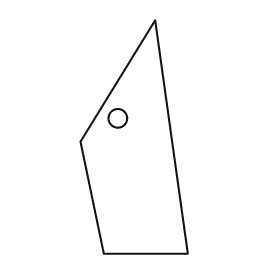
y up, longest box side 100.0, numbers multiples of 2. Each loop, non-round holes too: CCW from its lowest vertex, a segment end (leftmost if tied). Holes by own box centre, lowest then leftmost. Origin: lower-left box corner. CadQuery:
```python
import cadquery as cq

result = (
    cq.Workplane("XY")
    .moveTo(10.0, 0.0)
    .lineTo(46.0, 0.0)
    .lineTo(32.0, 100.0)
    .lineTo(0.0, 48.0)
    .close()
    .moveTo(16.0, 58.0)
    .circle(4.0)
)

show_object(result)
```